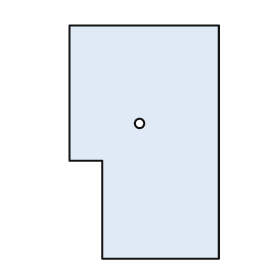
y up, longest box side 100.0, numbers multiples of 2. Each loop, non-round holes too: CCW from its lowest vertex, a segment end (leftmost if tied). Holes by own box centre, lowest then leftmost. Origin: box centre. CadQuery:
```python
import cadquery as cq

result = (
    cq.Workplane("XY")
    .moveTo(-18.0, -50.0)
    .lineTo(32.0, -50.0)
    .lineTo(32.0, 50.0)
    .lineTo(-32.0, 50.0)
    .lineTo(-32.0, -8.0)
    .lineTo(-18.0, -8.0)
    .close()
    .moveTo(-2.0, 8.0)
    .circle(2.0)
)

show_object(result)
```